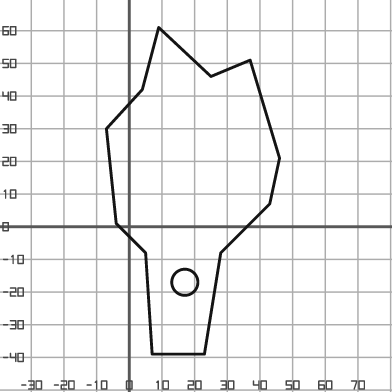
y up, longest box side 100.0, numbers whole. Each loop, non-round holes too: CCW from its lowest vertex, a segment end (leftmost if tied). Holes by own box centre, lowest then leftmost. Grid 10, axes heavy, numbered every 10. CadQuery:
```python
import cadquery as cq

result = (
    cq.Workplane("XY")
    .moveTo(7.0, -39.0)
    .lineTo(23.0, -39.0)
    .lineTo(28.0, -8.0)
    .lineTo(43.0, 7.0)
    .lineTo(46.0, 21.0)
    .lineTo(37.0, 51.0)
    .lineTo(25.0, 46.0)
    .lineTo(9.0, 61.0)
    .lineTo(4.0, 42.0)
    .lineTo(-7.0, 30.0)
    .lineTo(-4.0, 1.0)
    .lineTo(5.0, -8.0)
    .close()
    .moveTo(17.0, -17.0)
    .circle(4.0)
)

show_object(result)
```